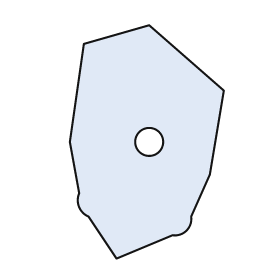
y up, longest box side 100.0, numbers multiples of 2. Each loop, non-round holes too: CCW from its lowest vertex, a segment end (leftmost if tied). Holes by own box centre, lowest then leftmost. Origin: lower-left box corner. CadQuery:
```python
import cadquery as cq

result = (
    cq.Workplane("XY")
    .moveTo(20.0, 0.0)
    .lineTo(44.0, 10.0)
    .threePointArc((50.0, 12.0), (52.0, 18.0))
    .lineTo(60.0, 36.0)
    .lineTo(66.0, 72.0)
    .lineTo(34.0, 100.0)
    .lineTo(6.0, 92.0)
    .lineTo(0.0, 50.0)
    .lineTo(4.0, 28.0)
    .threePointArc((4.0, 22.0), (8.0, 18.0))
    .close()
    .moveTo(34.0, 50.0)
    .circle(6.0)
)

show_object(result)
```